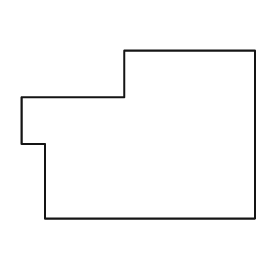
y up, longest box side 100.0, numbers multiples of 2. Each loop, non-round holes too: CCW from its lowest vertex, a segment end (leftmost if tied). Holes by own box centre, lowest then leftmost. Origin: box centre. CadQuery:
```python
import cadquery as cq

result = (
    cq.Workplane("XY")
    .moveTo(-40.0, -36.0)
    .lineTo(50.0, -36.0)
    .lineTo(50.0, 36.0)
    .lineTo(-6.0, 36.0)
    .lineTo(-6.0, 16.0)
    .lineTo(-50.0, 16.0)
    .lineTo(-50.0, -4.0)
    .lineTo(-40.0, -4.0)
    .close()
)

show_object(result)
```